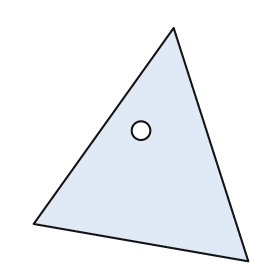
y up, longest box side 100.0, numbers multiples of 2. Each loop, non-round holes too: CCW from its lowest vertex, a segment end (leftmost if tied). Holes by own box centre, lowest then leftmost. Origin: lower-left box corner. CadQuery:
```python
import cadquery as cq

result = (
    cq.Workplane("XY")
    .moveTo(92.0, 0.0)
    .lineTo(60.0, 100.0)
    .lineTo(0.0, 16.0)
    .close()
    .moveTo(46.0, 56.0)
    .circle(4.0)
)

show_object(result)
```